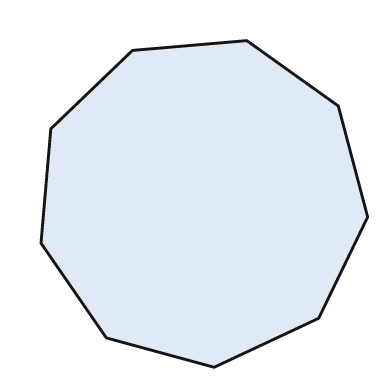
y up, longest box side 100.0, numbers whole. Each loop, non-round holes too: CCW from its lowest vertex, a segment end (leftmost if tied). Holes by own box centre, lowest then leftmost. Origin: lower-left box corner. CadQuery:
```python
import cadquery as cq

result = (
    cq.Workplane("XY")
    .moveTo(53.0, 0.0)
    .lineTo(85.0, 15.0)
    .lineTo(100.0, 46.0)
    .lineTo(91.0, 80.0)
    .lineTo(63.0, 100.0)
    .lineTo(28.0, 97.0)
    .lineTo(3.0, 73.0)
    .lineTo(0.0, 38.0)
    .lineTo(20.0, 9.0)
    .close()
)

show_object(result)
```